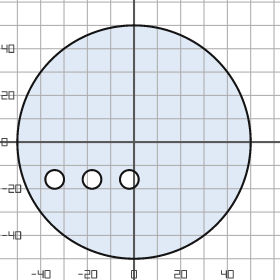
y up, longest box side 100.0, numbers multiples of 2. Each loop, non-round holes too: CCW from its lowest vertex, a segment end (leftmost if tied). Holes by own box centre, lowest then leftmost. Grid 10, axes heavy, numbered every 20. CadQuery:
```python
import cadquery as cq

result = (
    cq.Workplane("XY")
    .moveTo(0.0, 0.0)
    .circle(50.0)
    .moveTo(-34.0, -16.0)
    .circle(4.0)
    .moveTo(-18.0, -16.0)
    .circle(4.0)
    .moveTo(-2.0, -16.0)
    .circle(4.0)
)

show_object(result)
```